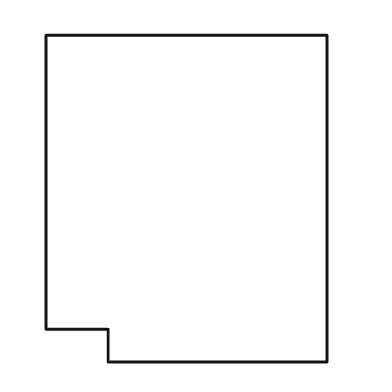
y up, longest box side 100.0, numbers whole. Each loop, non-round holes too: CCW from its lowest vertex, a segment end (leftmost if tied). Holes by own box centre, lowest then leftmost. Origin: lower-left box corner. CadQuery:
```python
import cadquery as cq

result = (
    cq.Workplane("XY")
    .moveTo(19.0, 0.0)
    .lineTo(86.0, 0.0)
    .lineTo(86.0, 100.0)
    .lineTo(0.0, 100.0)
    .lineTo(0.0, 10.0)
    .lineTo(19.0, 10.0)
    .close()
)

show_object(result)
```